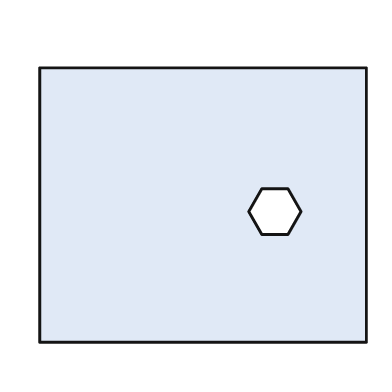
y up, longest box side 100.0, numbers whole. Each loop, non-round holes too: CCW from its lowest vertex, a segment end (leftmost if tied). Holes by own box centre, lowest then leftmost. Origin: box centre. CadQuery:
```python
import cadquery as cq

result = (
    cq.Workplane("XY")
    .moveTo(-50.0, -42.0)
    .lineTo(50.0, -42.0)
    .lineTo(50.0, 42.0)
    .lineTo(-50.0, 42.0)
    .close()
    .moveTo(18.0, -9.0)
    .lineTo(26.0, -9.0)
    .lineTo(30.0, -2.0)
    .lineTo(26.0, 5.0)
    .lineTo(18.0, 5.0)
    .lineTo(14.0, -2.0)
    .close()
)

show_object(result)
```